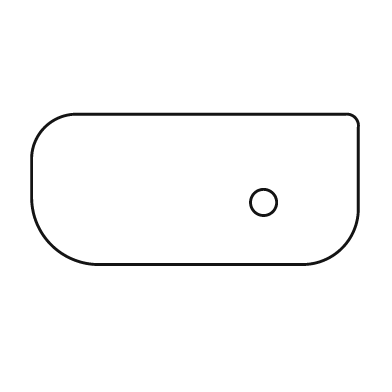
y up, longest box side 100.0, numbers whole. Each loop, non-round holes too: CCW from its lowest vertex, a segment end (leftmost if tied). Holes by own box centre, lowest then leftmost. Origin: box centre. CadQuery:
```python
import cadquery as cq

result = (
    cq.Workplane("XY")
    .moveTo(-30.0, -23.0)
    .lineTo(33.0, -23.0)
    .threePointArc((45.0, -18.0), (50.0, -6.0))
    .lineTo(50.0, 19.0)
    .threePointArc((49.0, 22.0), (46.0, 23.0))
    .lineTo(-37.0, 23.0)
    .threePointArc((-46.0, 19.0), (-50.0, 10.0))
    .lineTo(-50.0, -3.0)
    .threePointArc((-44.0, -17.0), (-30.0, -23.0))
    .close()
    .moveTo(21.0, -4.0)
    .circle(4.0)
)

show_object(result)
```